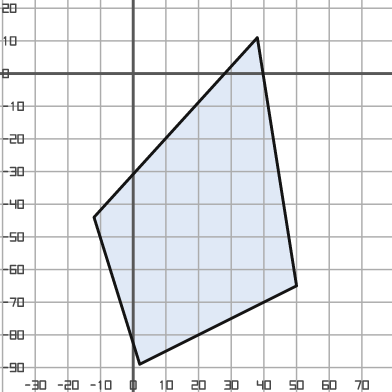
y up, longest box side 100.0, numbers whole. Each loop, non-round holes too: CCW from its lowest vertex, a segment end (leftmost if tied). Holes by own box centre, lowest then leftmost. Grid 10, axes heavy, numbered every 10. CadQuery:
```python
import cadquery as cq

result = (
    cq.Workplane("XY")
    .moveTo(2.0, -89.0)
    .lineTo(50.0, -65.0)
    .lineTo(38.0, 11.0)
    .lineTo(-12.0, -44.0)
    .close()
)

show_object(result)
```